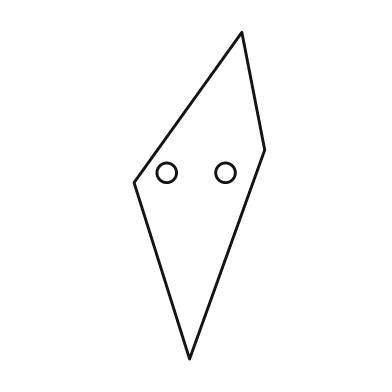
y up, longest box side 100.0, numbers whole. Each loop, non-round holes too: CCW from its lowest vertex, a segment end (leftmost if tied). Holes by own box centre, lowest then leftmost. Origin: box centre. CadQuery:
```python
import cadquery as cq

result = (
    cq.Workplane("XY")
    .moveTo(-3.0, -50.0)
    .lineTo(20.0, 14.0)
    .lineTo(13.0, 50.0)
    .lineTo(-20.0, 4.0)
    .close()
    .moveTo(-10.0, 7.0)
    .circle(3.0)
    .moveTo(8.0, 7.0)
    .circle(3.0)
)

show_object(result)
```